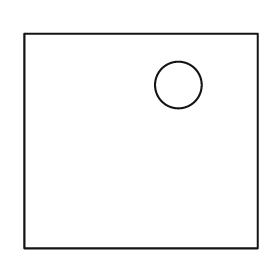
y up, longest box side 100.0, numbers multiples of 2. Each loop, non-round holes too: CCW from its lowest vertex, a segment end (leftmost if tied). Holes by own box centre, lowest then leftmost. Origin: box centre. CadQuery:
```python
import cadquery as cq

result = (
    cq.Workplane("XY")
    .moveTo(-50.0, -46.0)
    .lineTo(50.0, -46.0)
    .lineTo(50.0, 46.0)
    .lineTo(-50.0, 46.0)
    .close()
    .moveTo(16.0, 24.0)
    .circle(10.0)
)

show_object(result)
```